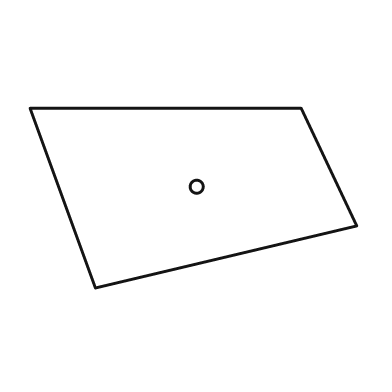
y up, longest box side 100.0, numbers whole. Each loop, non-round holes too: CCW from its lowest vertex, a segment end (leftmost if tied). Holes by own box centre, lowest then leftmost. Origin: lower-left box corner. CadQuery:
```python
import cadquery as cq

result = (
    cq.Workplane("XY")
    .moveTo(20.0, 0.0)
    .lineTo(100.0, 19.0)
    .lineTo(83.0, 55.0)
    .lineTo(0.0, 55.0)
    .close()
    .moveTo(51.0, 31.0)
    .circle(2.0)
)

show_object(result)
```